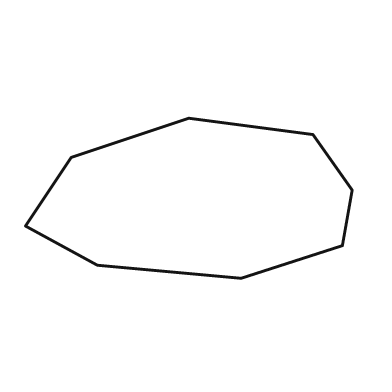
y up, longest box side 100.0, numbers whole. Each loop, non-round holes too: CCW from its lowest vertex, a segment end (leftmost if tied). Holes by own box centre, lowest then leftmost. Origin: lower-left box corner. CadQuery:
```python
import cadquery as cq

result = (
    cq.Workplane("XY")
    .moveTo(66.0, 0.0)
    .lineTo(97.0, 10.0)
    .lineTo(100.0, 27.0)
    .lineTo(88.0, 44.0)
    .lineTo(50.0, 49.0)
    .lineTo(14.0, 37.0)
    .lineTo(0.0, 16.0)
    .lineTo(22.0, 4.0)
    .close()
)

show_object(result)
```